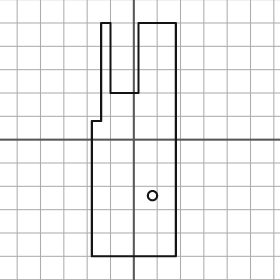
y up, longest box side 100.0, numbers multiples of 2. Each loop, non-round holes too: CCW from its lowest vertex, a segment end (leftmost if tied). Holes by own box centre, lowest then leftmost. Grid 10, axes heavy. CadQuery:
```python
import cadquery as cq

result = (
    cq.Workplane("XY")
    .moveTo(-18.0, -50.0)
    .lineTo(18.0, -50.0)
    .lineTo(18.0, 50.0)
    .lineTo(2.0, 50.0)
    .lineTo(2.0, 20.0)
    .lineTo(-10.0, 20.0)
    .lineTo(-10.0, 50.0)
    .lineTo(-14.0, 50.0)
    .lineTo(-14.0, 8.0)
    .lineTo(-18.0, 8.0)
    .close()
    .moveTo(8.0, -24.0)
    .circle(2.0)
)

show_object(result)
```